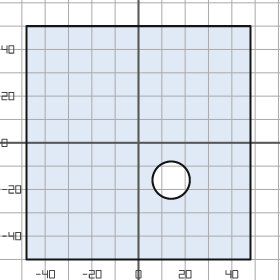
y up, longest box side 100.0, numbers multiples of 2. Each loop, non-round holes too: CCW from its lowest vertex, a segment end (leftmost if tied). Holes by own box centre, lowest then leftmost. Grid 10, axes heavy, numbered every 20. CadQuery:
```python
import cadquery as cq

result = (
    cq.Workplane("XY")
    .moveTo(-48.0, -50.0)
    .lineTo(48.0, -50.0)
    .lineTo(48.0, 50.0)
    .lineTo(-48.0, 50.0)
    .close()
    .moveTo(14.0, -16.0)
    .circle(8.0)
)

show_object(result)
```